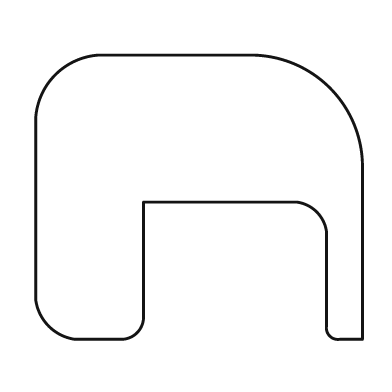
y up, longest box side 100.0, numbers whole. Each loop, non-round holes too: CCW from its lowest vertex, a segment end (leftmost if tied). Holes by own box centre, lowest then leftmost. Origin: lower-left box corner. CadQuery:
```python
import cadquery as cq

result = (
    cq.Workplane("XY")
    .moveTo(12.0, 0.0)
    .lineTo(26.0, 0.0)
    .threePointArc((31.0, 2.0), (33.0, 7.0))
    .lineTo(33.0, 42.0)
    .lineTo(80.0, 42.0)
    .threePointArc((86.0, 39.0), (89.0, 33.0))
    .lineTo(89.0, 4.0)
    .threePointArc((90.0, 1.0), (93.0, 0.0))
    .lineTo(100.0, 0.0)
    .lineTo(100.0, 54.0)
    .threePointArc((90.0, 77.0), (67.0, 87.0))
    .lineTo(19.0, 87.0)
    .threePointArc((6.0, 81.0), (0.0, 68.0))
    .lineTo(0.0, 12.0)
    .threePointArc((4.0, 4.0), (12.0, 0.0))
    .close()
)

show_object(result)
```